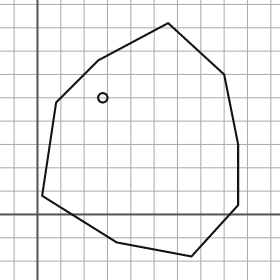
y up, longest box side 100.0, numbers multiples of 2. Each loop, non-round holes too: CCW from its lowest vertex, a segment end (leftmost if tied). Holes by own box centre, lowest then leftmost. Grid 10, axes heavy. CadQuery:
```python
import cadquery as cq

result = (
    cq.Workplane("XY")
    .moveTo(66.0, -18.0)
    .lineTo(86.0, 4.0)
    .lineTo(86.0, 30.0)
    .lineTo(80.0, 60.0)
    .lineTo(56.0, 82.0)
    .lineTo(26.0, 66.0)
    .lineTo(8.0, 48.0)
    .lineTo(2.0, 8.0)
    .lineTo(34.0, -12.0)
    .close()
    .moveTo(28.0, 50.0)
    .circle(2.0)
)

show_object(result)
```